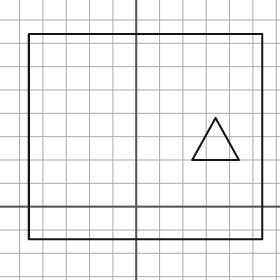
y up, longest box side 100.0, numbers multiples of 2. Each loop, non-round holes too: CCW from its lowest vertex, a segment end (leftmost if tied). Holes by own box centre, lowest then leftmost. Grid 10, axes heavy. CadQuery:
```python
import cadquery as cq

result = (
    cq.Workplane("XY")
    .moveTo(-46.0, -14.0)
    .lineTo(54.0, -14.0)
    .lineTo(54.0, 74.0)
    .lineTo(-46.0, 74.0)
    .close()
    .moveTo(24.0, 20.0)
    .lineTo(44.0, 20.0)
    .lineTo(34.0, 38.0)
    .close()
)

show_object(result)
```